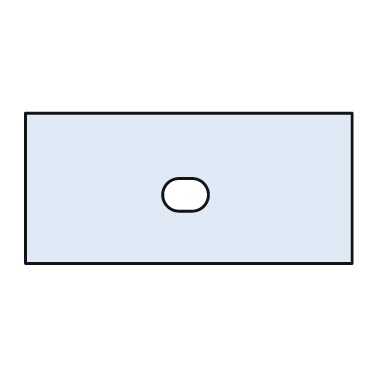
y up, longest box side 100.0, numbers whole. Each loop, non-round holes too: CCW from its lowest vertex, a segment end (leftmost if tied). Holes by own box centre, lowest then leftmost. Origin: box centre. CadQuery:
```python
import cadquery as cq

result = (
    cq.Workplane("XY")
    .moveTo(-50.0, -23.0)
    .lineTo(50.0, -23.0)
    .lineTo(50.0, 23.0)
    .lineTo(-50.0, 23.0)
    .close()
    .moveTo(-3.0, -7.0)
    .lineTo(1.0, -7.0)
    .threePointArc((6.0, -2.0), (1.0, 3.0))
    .lineTo(-3.0, 3.0)
    .threePointArc((-8.0, -2.0), (-3.0, -7.0))
    .close()
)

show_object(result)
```